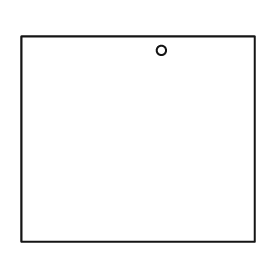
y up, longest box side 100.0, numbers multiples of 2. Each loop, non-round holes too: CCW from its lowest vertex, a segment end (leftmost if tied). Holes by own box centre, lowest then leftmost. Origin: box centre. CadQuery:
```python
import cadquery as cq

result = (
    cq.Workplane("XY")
    .moveTo(-50.0, -44.0)
    .lineTo(50.0, -44.0)
    .lineTo(50.0, 44.0)
    .lineTo(-50.0, 44.0)
    .close()
    .moveTo(10.0, 38.0)
    .circle(2.0)
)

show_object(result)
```